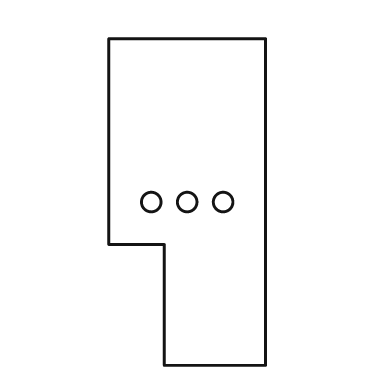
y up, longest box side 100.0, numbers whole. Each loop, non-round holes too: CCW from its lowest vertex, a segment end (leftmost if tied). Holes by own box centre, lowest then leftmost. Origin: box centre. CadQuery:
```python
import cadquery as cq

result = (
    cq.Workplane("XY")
    .moveTo(-7.0, -50.0)
    .lineTo(24.0, -50.0)
    .lineTo(24.0, 50.0)
    .lineTo(-24.0, 50.0)
    .lineTo(-24.0, -13.0)
    .lineTo(-7.0, -13.0)
    .close()
    .moveTo(-11.0, 0.0)
    .circle(3.0)
    .moveTo(0.0, 0.0)
    .circle(3.0)
    .moveTo(11.0, 0.0)
    .circle(3.0)
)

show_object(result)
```